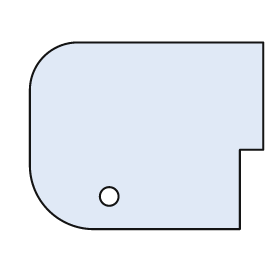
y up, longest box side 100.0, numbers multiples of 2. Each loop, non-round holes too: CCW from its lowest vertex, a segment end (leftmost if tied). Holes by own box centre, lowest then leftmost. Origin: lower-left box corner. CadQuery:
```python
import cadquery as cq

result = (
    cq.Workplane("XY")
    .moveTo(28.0, 0.0)
    .lineTo(90.0, 0.0)
    .lineTo(90.0, 34.0)
    .lineTo(100.0, 34.0)
    .lineTo(100.0, 80.0)
    .lineTo(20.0, 80.0)
    .threePointArc((6.0, 74.0), (0.0, 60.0))
    .lineTo(0.0, 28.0)
    .threePointArc((8.0, 8.0), (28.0, 0.0))
    .close()
    .moveTo(34.0, 14.0)
    .circle(4.0)
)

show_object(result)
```